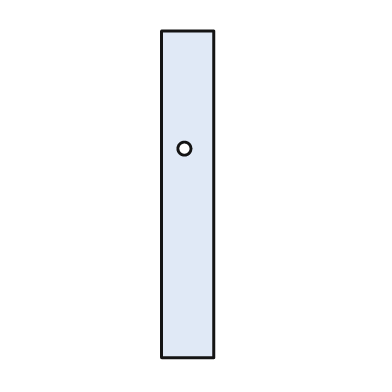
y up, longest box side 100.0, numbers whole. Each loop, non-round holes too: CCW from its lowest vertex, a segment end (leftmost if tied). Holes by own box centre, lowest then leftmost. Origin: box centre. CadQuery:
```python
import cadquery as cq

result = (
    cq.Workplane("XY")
    .moveTo(-8.0, -50.0)
    .lineTo(8.0, -50.0)
    .lineTo(8.0, 50.0)
    .lineTo(-8.0, 50.0)
    .close()
    .moveTo(-1.0, 14.0)
    .circle(2.0)
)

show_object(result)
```